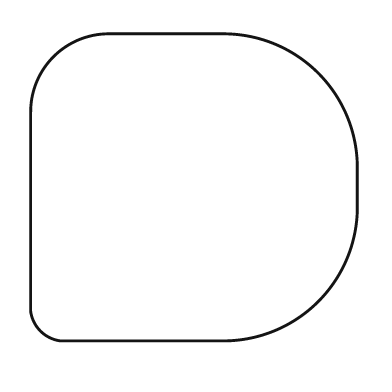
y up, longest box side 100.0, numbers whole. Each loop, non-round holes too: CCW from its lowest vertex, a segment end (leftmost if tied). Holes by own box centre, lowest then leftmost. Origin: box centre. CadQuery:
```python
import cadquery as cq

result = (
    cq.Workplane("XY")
    .moveTo(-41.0, -47.0)
    .lineTo(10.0, -47.0)
    .threePointArc((38.0, -35.0), (50.0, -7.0))
    .lineTo(50.0, 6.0)
    .threePointArc((38.0, 35.0), (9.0, 47.0))
    .lineTo(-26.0, 47.0)
    .threePointArc((-43.0, 40.0), (-50.0, 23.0))
    .lineTo(-50.0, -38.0)
    .threePointArc((-47.0, -44.0), (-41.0, -47.0))
    .close()
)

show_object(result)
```